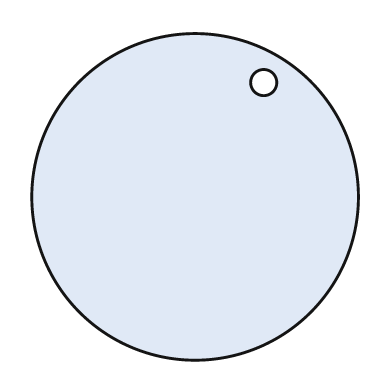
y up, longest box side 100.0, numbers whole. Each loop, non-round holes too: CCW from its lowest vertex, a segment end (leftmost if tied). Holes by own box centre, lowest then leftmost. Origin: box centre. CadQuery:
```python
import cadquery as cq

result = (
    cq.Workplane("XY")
    .moveTo(0.0, 0.0)
    .circle(50.0)
    .moveTo(21.0, 35.0)
    .circle(4.0)
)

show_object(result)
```